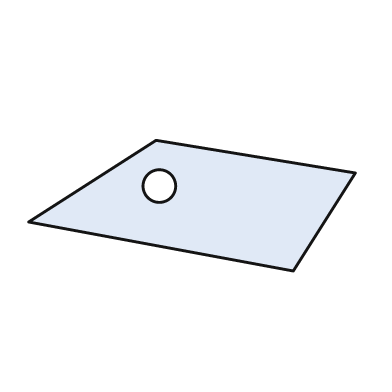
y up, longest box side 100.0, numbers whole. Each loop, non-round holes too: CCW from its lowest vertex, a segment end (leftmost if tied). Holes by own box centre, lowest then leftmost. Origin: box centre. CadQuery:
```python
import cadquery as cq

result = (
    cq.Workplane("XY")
    .moveTo(31.0, -20.0)
    .lineTo(50.0, 10.0)
    .lineTo(-11.0, 20.0)
    .lineTo(-50.0, -5.0)
    .close()
    .moveTo(-10.0, 6.0)
    .circle(5.0)
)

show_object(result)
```